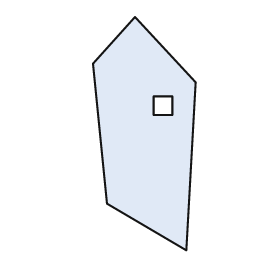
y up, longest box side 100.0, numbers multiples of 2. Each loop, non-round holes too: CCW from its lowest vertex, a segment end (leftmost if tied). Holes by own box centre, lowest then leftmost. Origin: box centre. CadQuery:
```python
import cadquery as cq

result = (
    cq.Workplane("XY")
    .moveTo(18.0, -50.0)
    .lineTo(22.0, 22.0)
    .lineTo(-4.0, 50.0)
    .lineTo(-22.0, 30.0)
    .lineTo(-16.0, -30.0)
    .close()
    .moveTo(4.0, 8.0)
    .lineTo(12.0, 8.0)
    .lineTo(12.0, 16.0)
    .lineTo(4.0, 16.0)
    .close()
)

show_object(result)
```